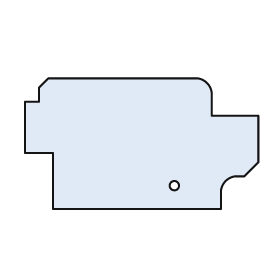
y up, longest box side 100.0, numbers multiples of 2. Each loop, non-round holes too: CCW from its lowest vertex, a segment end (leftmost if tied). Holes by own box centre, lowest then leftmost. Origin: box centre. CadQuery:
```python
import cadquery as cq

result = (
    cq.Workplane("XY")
    .moveTo(-38.0, -28.0)
    .lineTo(34.0, -28.0)
    .lineTo(34.0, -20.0)
    .threePointArc((36.0, -16.0), (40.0, -14.0))
    .lineTo(44.0, -14.0)
    .lineTo(50.0, -8.0)
    .lineTo(50.0, 12.0)
    .lineTo(30.0, 12.0)
    .lineTo(30.0, 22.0)
    .threePointArc((28.0, 26.0), (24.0, 28.0))
    .lineTo(-40.0, 28.0)
    .lineTo(-44.0, 24.0)
    .lineTo(-44.0, 18.0)
    .lineTo(-50.0, 18.0)
    .lineTo(-50.0, -4.0)
    .lineTo(-38.0, -4.0)
    .close()
    .moveTo(14.0, -18.0)
    .circle(2.0)
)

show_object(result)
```